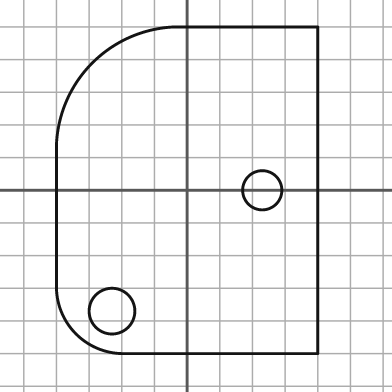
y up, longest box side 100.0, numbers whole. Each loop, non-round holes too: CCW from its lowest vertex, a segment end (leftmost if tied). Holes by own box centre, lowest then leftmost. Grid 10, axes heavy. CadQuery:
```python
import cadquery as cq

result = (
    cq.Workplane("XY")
    .moveTo(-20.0, -50.0)
    .lineTo(40.0, -50.0)
    .lineTo(40.0, 50.0)
    .lineTo(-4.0, 50.0)
    .threePointArc((-29.0, 39.0), (-40.0, 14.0))
    .lineTo(-40.0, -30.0)
    .threePointArc((-34.0, -44.0), (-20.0, -50.0))
    .close()
    .moveTo(-23.0, -37.0)
    .circle(7.0)
    .moveTo(23.0, 0.0)
    .circle(6.0)
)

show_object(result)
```